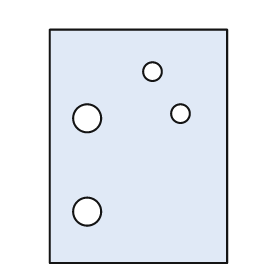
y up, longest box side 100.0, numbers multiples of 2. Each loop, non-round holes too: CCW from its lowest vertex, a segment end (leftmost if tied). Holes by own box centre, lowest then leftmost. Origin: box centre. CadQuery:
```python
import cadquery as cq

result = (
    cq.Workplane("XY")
    .moveTo(-38.0, -50.0)
    .lineTo(38.0, -50.0)
    .lineTo(38.0, 50.0)
    .lineTo(-38.0, 50.0)
    .close()
    .moveTo(-22.0, -28.0)
    .circle(6.0)
    .moveTo(-22.0, 12.0)
    .circle(6.0)
    .moveTo(18.0, 14.0)
    .circle(4.0)
    .moveTo(6.0, 32.0)
    .circle(4.0)
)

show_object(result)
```